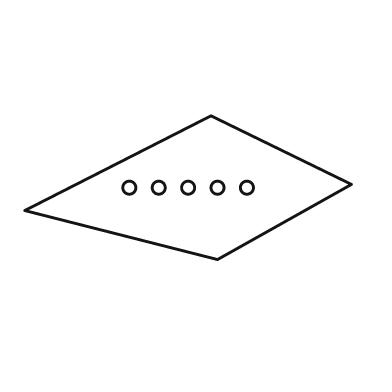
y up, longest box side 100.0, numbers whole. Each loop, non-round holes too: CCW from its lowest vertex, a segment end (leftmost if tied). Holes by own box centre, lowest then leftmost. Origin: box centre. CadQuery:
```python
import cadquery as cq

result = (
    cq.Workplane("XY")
    .moveTo(9.0, -22.0)
    .lineTo(50.0, 1.0)
    .lineTo(7.0, 22.0)
    .lineTo(-50.0, -7.0)
    .close()
    .moveTo(-18.0, 0.0)
    .circle(2.0)
    .moveTo(-9.0, 0.0)
    .circle(2.0)
    .moveTo(0.0, 0.0)
    .circle(2.0)
    .moveTo(9.0, 0.0)
    .circle(2.0)
    .moveTo(18.0, 0.0)
    .circle(2.0)
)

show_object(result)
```